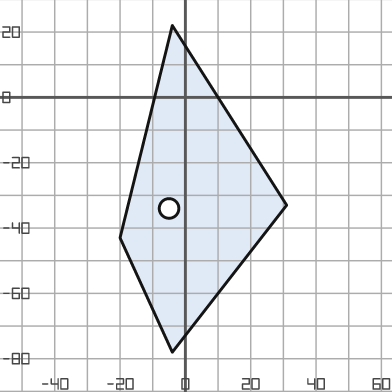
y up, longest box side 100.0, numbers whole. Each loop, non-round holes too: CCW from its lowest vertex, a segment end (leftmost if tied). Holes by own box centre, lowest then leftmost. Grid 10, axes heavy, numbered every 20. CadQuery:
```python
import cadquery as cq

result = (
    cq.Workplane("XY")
    .moveTo(-4.0, -78.0)
    .lineTo(31.0, -33.0)
    .lineTo(-4.0, 22.0)
    .lineTo(-20.0, -43.0)
    .close()
    .moveTo(-5.0, -34.0)
    .circle(3.0)
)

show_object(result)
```